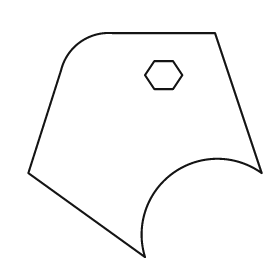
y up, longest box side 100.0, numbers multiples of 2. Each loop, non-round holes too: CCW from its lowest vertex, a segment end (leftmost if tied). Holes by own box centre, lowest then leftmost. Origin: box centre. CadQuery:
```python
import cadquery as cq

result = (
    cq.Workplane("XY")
    .moveTo(0.0, -48.0)
    .threePointArc((12.0, -12.0), (50.0, -12.0))
    .lineTo(30.0, 48.0)
    .lineTo(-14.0, 48.0)
    .threePointArc((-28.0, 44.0), (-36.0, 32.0))
    .lineTo(-50.0, -12.0)
    .close()
    .moveTo(4.0, 24.0)
    .lineTo(12.0, 24.0)
    .lineTo(16.0, 30.0)
    .lineTo(12.0, 36.0)
    .lineTo(4.0, 36.0)
    .lineTo(0.0, 30.0)
    .close()
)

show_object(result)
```